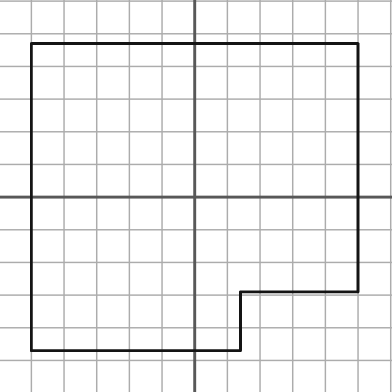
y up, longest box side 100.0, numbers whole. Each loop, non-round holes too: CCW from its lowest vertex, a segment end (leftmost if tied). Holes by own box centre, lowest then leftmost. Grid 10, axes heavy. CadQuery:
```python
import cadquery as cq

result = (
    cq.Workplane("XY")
    .moveTo(-50.0, -47.0)
    .lineTo(14.0, -47.0)
    .lineTo(14.0, -29.0)
    .lineTo(50.0, -29.0)
    .lineTo(50.0, 47.0)
    .lineTo(-50.0, 47.0)
    .close()
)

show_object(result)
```